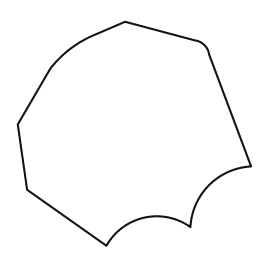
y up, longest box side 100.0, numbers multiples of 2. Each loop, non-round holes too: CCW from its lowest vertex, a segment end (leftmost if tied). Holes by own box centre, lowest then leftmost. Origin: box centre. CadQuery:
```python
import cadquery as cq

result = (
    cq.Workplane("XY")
    .moveTo(-12.0, -48.0)
    .threePointArc((4.0, -36.0), (24.0, -40.0))
    .threePointArc((32.0, -22.0), (50.0, -14.0))
    .lineTo(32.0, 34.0)
    .threePointArc((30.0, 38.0), (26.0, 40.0))
    .lineTo(-4.0, 48.0)
    .lineTo(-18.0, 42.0)
    .threePointArc((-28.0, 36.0), (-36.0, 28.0))
    .lineTo(-50.0, 4.0)
    .lineTo(-46.0, -24.0)
    .close()
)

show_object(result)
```